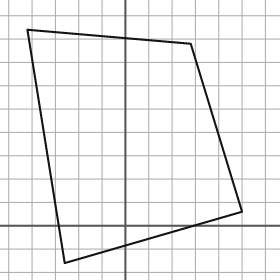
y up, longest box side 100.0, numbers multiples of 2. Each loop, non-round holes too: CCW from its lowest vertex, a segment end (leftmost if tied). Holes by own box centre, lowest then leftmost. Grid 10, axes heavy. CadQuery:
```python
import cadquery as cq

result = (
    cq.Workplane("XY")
    .moveTo(-26.0, -16.0)
    .lineTo(50.0, 6.0)
    .lineTo(28.0, 78.0)
    .lineTo(-42.0, 84.0)
    .close()
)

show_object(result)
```